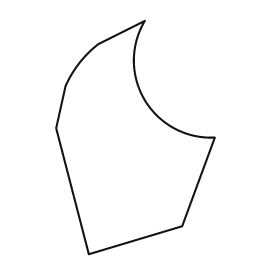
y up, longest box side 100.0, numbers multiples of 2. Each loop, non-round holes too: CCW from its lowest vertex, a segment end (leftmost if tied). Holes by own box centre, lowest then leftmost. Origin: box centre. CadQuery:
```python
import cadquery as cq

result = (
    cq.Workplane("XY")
    .moveTo(-20.0, -50.0)
    .lineTo(20.0, -38.0)
    .lineTo(34.0, 0.0)
    .threePointArc((4.0, 16.0), (4.0, 50.0))
    .lineTo(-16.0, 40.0)
    .threePointArc((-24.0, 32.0), (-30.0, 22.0))
    .lineTo(-34.0, 4.0)
    .close()
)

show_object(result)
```